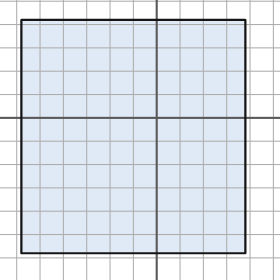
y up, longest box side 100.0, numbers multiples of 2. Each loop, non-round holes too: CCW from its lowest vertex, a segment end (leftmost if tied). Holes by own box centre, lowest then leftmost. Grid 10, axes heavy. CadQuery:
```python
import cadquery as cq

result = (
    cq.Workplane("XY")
    .moveTo(-58.0, -58.0)
    .lineTo(38.0, -58.0)
    .lineTo(38.0, 42.0)
    .lineTo(-58.0, 42.0)
    .close()
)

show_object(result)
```